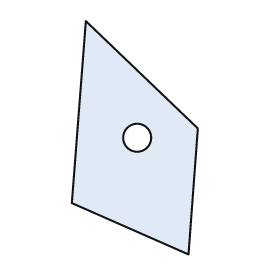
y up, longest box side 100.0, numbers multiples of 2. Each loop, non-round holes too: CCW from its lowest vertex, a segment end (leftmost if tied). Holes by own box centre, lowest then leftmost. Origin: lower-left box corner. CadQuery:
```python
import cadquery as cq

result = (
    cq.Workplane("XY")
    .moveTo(50.0, 0.0)
    .lineTo(54.0, 54.0)
    .lineTo(6.0, 100.0)
    .lineTo(0.0, 22.0)
    .close()
    .moveTo(28.0, 50.0)
    .circle(6.0)
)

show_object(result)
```